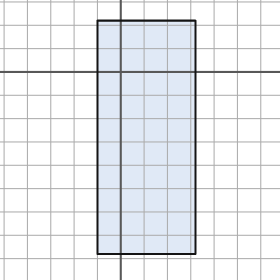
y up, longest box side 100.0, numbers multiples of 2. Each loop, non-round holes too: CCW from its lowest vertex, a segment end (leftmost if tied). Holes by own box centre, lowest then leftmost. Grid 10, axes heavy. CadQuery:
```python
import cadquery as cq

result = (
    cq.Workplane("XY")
    .moveTo(-10.0, -78.0)
    .lineTo(32.0, -78.0)
    .lineTo(32.0, 22.0)
    .lineTo(-10.0, 22.0)
    .close()
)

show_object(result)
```